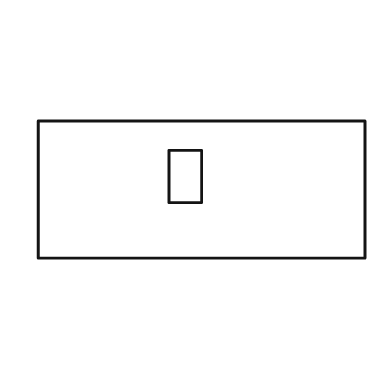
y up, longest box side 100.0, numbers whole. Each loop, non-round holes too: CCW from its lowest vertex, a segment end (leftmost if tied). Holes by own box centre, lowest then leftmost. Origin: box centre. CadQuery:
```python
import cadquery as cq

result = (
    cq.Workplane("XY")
    .moveTo(-50.0, -21.0)
    .lineTo(50.0, -21.0)
    .lineTo(50.0, 21.0)
    .lineTo(-50.0, 21.0)
    .close()
    .moveTo(-10.0, -4.0)
    .lineTo(0.0, -4.0)
    .lineTo(0.0, 12.0)
    .lineTo(-10.0, 12.0)
    .close()
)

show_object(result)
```